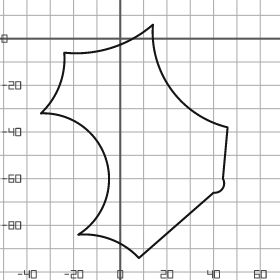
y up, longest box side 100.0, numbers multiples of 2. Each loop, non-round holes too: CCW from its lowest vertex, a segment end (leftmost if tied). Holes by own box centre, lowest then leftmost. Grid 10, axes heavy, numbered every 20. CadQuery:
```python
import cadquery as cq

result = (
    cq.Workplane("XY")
    .moveTo(8.0, -94.0)
    .lineTo(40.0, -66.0)
    .threePointArc((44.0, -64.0), (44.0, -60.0))
    .lineTo(46.0, -38.0)
    .threePointArc((22.0, -22.0), (14.0, 6.0))
    .threePointArc((-4.0, -4.0), (-24.0, -6.0))
    .threePointArc((-26.0, -20.0), (-34.0, -32.0))
    .threePointArc((-6.0, -52.0), (-18.0, -84.0))
    .threePointArc((-4.0, -86.0), (8.0, -94.0))
    .close()
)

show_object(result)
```